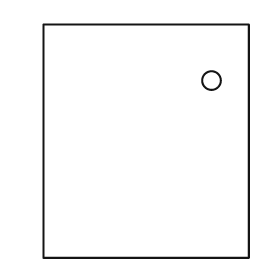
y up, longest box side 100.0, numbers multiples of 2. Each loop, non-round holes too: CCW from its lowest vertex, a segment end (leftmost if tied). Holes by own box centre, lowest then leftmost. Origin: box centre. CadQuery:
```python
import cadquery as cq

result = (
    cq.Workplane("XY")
    .moveTo(-44.0, -50.0)
    .lineTo(44.0, -50.0)
    .lineTo(44.0, 50.0)
    .lineTo(-44.0, 50.0)
    .close()
    .moveTo(28.0, 26.0)
    .circle(4.0)
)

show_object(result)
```